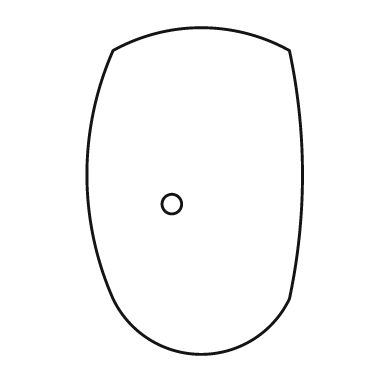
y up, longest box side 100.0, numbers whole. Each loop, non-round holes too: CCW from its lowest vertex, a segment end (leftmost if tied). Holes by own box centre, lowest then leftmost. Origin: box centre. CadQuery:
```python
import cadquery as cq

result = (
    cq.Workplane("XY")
    .moveTo(-25.0, -33.0)
    .threePointArc((2.0, -50.0), (29.0, -33.0))
    .threePointArc((33.0, 5.0), (29.0, 43.0))
    .threePointArc((2.0, 50.0), (-25.0, 43.0))
    .threePointArc((-33.0, 5.0), (-25.0, -33.0))
    .close()
    .moveTo(-7.0, -4.0)
    .circle(3.0)
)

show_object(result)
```